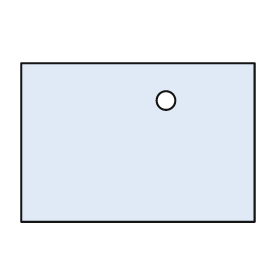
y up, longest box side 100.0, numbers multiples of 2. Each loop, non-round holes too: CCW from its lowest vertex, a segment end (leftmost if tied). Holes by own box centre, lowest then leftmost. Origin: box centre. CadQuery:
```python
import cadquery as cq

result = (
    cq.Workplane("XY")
    .moveTo(-50.0, -34.0)
    .lineTo(50.0, -34.0)
    .lineTo(50.0, 34.0)
    .lineTo(-50.0, 34.0)
    .close()
    .moveTo(12.0, 18.0)
    .circle(4.0)
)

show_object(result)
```